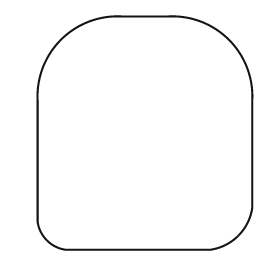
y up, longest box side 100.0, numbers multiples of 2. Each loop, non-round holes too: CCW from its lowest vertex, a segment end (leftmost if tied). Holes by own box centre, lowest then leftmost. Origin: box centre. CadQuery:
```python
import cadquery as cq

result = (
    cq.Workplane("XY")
    .moveTo(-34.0, -50.0)
    .lineTo(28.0, -50.0)
    .threePointArc((40.0, -44.0), (46.0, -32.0))
    .lineTo(46.0, 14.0)
    .threePointArc((36.0, 40.0), (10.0, 50.0))
    .lineTo(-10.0, 50.0)
    .threePointArc((-36.0, 40.0), (-46.0, 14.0))
    .lineTo(-46.0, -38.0)
    .threePointArc((-42.0, -46.0), (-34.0, -50.0))
    .close()
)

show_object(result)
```